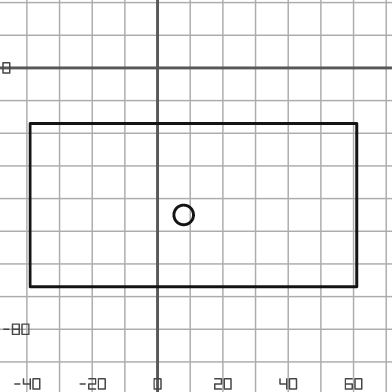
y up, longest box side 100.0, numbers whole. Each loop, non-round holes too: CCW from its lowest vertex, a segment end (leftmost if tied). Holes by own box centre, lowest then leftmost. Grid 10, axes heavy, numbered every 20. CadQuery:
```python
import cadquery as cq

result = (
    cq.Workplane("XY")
    .moveTo(-39.0, -67.0)
    .lineTo(61.0, -67.0)
    .lineTo(61.0, -17.0)
    .lineTo(-39.0, -17.0)
    .close()
    .moveTo(8.0, -45.0)
    .circle(3.0)
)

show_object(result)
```